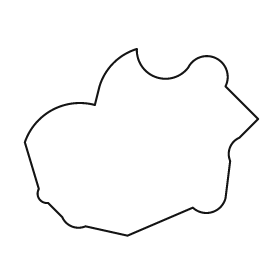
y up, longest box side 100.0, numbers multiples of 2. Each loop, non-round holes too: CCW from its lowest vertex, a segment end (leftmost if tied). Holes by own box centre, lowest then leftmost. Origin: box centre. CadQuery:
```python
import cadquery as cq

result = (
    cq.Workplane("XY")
    .moveTo(-6.0, -40.0)
    .lineTo(22.0, -28.0)
    .threePointArc((30.0, -30.0), (36.0, -24.0))
    .lineTo(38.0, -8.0)
    .threePointArc((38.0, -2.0), (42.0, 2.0))
    .lineTo(50.0, 10.0)
    .lineTo(36.0, 24.0)
    .threePointArc((32.0, 36.0), (20.0, 32.0))
    .threePointArc((6.0, 28.0), (-2.0, 40.0))
    .threePointArc((-12.0, 34.0), (-18.0, 24.0))
    .lineTo(-20.0, 16.0)
    .threePointArc((-38.0, 14.0), (-50.0, 0.0))
    .lineTo(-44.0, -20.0)
    .threePointArc((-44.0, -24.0), (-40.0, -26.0))
    .lineTo(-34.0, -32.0)
    .threePointArc((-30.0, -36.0), (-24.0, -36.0))
    .close()
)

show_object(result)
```